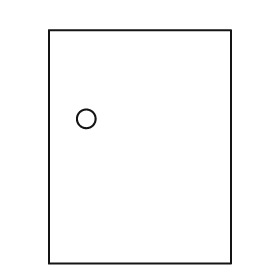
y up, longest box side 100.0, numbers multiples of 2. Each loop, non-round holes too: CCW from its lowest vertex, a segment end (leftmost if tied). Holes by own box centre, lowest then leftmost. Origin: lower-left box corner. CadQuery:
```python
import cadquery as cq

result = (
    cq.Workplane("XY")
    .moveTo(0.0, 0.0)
    .lineTo(78.0, 0.0)
    .lineTo(78.0, 100.0)
    .lineTo(0.0, 100.0)
    .close()
    .moveTo(16.0, 62.0)
    .circle(4.0)
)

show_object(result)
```